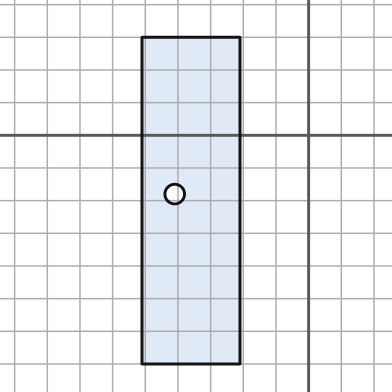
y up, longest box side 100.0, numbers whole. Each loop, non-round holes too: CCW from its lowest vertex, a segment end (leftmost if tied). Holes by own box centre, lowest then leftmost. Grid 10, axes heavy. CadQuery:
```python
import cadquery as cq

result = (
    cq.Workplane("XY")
    .moveTo(-51.0, -70.0)
    .lineTo(-21.0, -70.0)
    .lineTo(-21.0, 30.0)
    .lineTo(-51.0, 30.0)
    .close()
    .moveTo(-41.0, -18.0)
    .circle(3.0)
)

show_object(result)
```